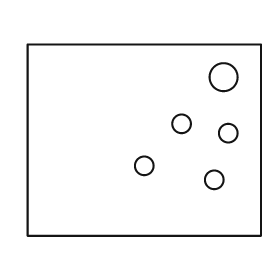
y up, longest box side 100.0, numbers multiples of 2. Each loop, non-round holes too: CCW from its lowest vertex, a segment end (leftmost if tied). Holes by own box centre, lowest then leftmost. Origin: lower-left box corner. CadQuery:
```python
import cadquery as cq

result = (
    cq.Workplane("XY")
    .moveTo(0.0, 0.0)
    .lineTo(100.0, 0.0)
    .lineTo(100.0, 82.0)
    .lineTo(0.0, 82.0)
    .close()
    .moveTo(80.0, 24.0)
    .circle(4.0)
    .moveTo(50.0, 30.0)
    .circle(4.0)
    .moveTo(86.0, 44.0)
    .circle(4.0)
    .moveTo(66.0, 48.0)
    .circle(4.0)
    .moveTo(84.0, 68.0)
    .circle(6.0)
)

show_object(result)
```